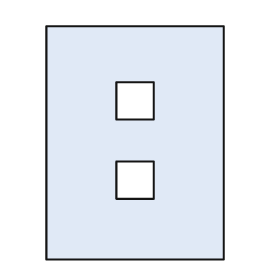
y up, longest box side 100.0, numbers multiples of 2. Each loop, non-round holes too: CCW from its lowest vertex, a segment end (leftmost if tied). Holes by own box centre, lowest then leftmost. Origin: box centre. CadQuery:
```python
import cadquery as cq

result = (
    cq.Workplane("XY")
    .moveTo(-38.0, -50.0)
    .lineTo(38.0, -50.0)
    .lineTo(38.0, 50.0)
    .lineTo(-38.0, 50.0)
    .close()
    .moveTo(-8.0, -24.0)
    .lineTo(8.0, -24.0)
    .lineTo(8.0, -8.0)
    .lineTo(-8.0, -8.0)
    .close()
    .moveTo(-8.0, 10.0)
    .lineTo(8.0, 10.0)
    .lineTo(8.0, 26.0)
    .lineTo(-8.0, 26.0)
    .close()
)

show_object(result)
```